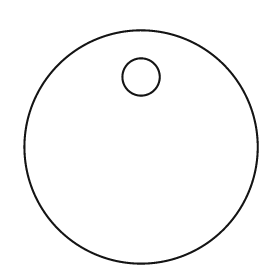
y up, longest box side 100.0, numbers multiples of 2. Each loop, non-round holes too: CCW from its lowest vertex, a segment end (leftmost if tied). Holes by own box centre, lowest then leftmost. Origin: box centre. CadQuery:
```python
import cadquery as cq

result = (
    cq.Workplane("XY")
    .moveTo(0.0, 0.0)
    .circle(50.0)
    .moveTo(0.0, 30.0)
    .circle(8.0)
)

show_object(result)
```